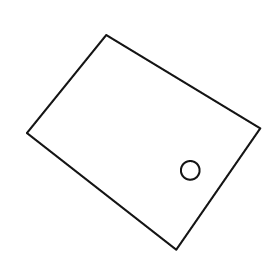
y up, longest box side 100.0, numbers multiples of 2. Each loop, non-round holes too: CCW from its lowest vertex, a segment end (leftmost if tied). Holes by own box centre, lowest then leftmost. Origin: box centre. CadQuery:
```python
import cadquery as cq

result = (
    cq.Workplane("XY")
    .moveTo(14.0, -46.0)
    .lineTo(50.0, 6.0)
    .lineTo(-16.0, 46.0)
    .lineTo(-50.0, 4.0)
    .close()
    .moveTo(20.0, -12.0)
    .circle(4.0)
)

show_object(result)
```